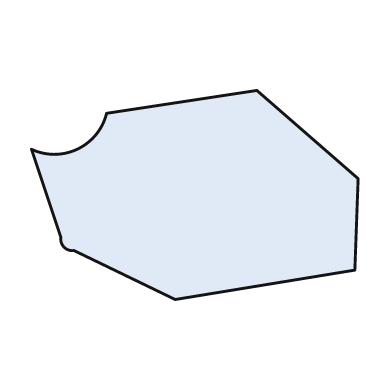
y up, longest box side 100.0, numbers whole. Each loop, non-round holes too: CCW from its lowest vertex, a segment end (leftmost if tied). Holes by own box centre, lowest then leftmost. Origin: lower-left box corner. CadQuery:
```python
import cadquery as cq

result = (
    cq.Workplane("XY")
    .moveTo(44.0, 0.0)
    .lineTo(99.0, 9.0)
    .lineTo(100.0, 37.0)
    .lineTo(69.0, 64.0)
    .lineTo(23.0, 57.0)
    .threePointArc((14.0, 46.0), (0.0, 46.0))
    .lineTo(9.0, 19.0)
    .threePointArc((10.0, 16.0), (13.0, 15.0))
    .close()
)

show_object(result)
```